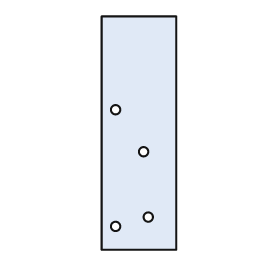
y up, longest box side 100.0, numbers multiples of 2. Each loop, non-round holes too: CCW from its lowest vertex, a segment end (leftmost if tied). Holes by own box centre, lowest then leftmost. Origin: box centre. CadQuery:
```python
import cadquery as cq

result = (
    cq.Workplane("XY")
    .moveTo(-16.0, -50.0)
    .lineTo(16.0, -50.0)
    .lineTo(16.0, 50.0)
    .lineTo(-16.0, 50.0)
    .close()
    .moveTo(-10.0, -40.0)
    .circle(2.0)
    .moveTo(4.0, -36.0)
    .circle(2.0)
    .moveTo(2.0, -8.0)
    .circle(2.0)
    .moveTo(-10.0, 10.0)
    .circle(2.0)
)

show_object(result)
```